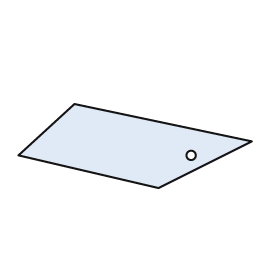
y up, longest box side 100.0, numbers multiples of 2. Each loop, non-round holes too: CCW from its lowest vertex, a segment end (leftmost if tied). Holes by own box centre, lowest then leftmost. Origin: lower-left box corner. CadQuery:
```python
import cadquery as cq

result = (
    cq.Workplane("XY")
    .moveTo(60.0, 0.0)
    .lineTo(100.0, 20.0)
    .lineTo(24.0, 36.0)
    .lineTo(0.0, 14.0)
    .close()
    .moveTo(74.0, 14.0)
    .circle(2.0)
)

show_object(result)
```